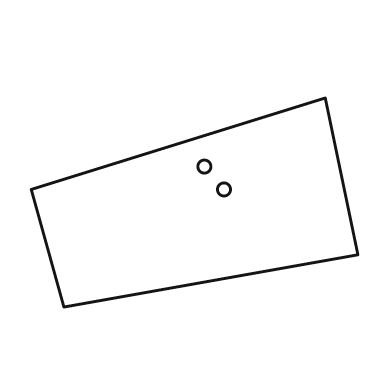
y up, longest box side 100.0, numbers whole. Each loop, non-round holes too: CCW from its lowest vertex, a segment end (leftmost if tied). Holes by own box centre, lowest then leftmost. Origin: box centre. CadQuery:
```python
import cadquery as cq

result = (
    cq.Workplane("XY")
    .moveTo(-40.0, -32.0)
    .lineTo(50.0, -16.0)
    .lineTo(40.0, 32.0)
    .lineTo(-50.0, 4.0)
    .close()
    .moveTo(9.0, 4.0)
    .circle(2.0)
    .moveTo(3.0, 11.0)
    .circle(2.0)
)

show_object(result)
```